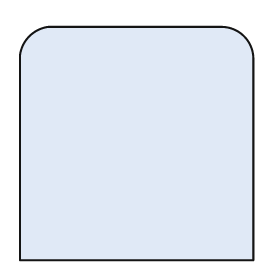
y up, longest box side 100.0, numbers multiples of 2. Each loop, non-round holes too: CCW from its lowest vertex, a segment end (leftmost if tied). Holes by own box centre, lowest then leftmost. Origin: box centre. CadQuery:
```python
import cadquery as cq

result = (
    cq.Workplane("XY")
    .moveTo(-50.0, -50.0)
    .lineTo(50.0, -50.0)
    .lineTo(50.0, 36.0)
    .threePointArc((46.0, 46.0), (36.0, 50.0))
    .lineTo(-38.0, 50.0)
    .threePointArc((-46.0, 46.0), (-50.0, 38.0))
    .close()
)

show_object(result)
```